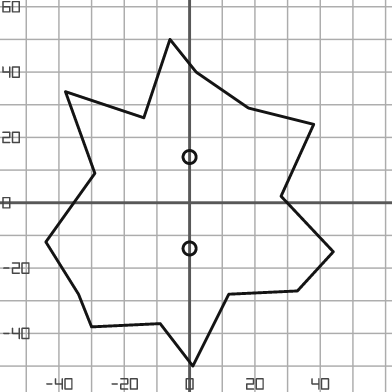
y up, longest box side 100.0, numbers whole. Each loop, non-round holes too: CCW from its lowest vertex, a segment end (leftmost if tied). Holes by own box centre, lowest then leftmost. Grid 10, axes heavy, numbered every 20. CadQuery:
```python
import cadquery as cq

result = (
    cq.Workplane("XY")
    .moveTo(1.0, -50.0)
    .lineTo(12.0, -28.0)
    .lineTo(33.0, -27.0)
    .lineTo(44.0, -15.0)
    .lineTo(28.0, 2.0)
    .lineTo(38.0, 24.0)
    .lineTo(18.0, 29.0)
    .lineTo(2.0, 40.0)
    .lineTo(-6.0, 50.0)
    .lineTo(-14.0, 26.0)
    .lineTo(-38.0, 34.0)
    .lineTo(-29.0, 9.0)
    .lineTo(-44.0, -12.0)
    .lineTo(-34.0, -28.0)
    .lineTo(-30.0, -38.0)
    .lineTo(-9.0, -37.0)
    .close()
    .moveTo(0.0, -14.0)
    .circle(2.0)
    .moveTo(0.0, 14.0)
    .circle(2.0)
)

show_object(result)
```